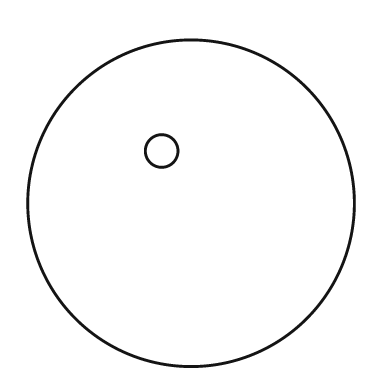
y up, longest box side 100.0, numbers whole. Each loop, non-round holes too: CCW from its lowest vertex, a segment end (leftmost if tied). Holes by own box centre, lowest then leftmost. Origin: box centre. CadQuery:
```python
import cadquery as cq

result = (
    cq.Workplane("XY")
    .moveTo(0.0, 0.0)
    .circle(50.0)
    .moveTo(-9.0, 16.0)
    .circle(5.0)
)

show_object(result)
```